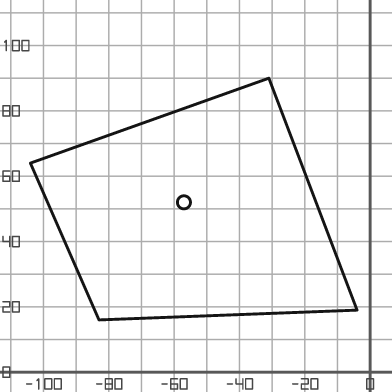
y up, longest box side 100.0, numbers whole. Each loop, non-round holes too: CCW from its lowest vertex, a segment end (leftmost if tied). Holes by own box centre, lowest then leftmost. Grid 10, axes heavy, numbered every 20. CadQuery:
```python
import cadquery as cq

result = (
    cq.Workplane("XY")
    .moveTo(-83.0, 16.0)
    .lineTo(-4.0, 19.0)
    .lineTo(-31.0, 90.0)
    .lineTo(-104.0, 64.0)
    .close()
    .moveTo(-57.0, 52.0)
    .circle(2.0)
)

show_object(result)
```